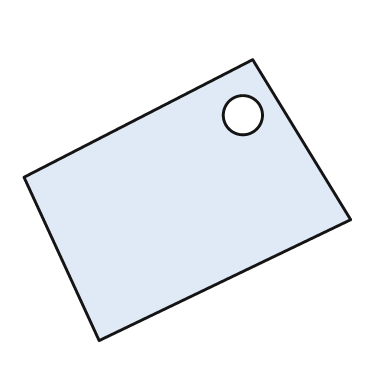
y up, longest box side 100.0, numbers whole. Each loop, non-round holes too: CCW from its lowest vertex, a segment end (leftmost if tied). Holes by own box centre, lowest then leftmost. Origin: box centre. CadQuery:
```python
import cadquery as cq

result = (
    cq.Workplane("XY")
    .moveTo(-27.0, -43.0)
    .lineTo(50.0, -6.0)
    .lineTo(20.0, 43.0)
    .lineTo(-50.0, 7.0)
    .close()
    .moveTo(17.0, 26.0)
    .circle(6.0)
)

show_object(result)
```